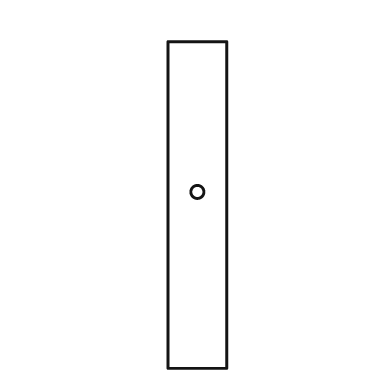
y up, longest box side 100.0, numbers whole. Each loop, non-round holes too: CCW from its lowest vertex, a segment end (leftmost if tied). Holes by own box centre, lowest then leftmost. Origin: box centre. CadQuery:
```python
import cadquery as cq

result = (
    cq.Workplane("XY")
    .moveTo(-9.0, -50.0)
    .lineTo(9.0, -50.0)
    .lineTo(9.0, 50.0)
    .lineTo(-9.0, 50.0)
    .close()
    .moveTo(0.0, 4.0)
    .circle(2.0)
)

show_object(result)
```